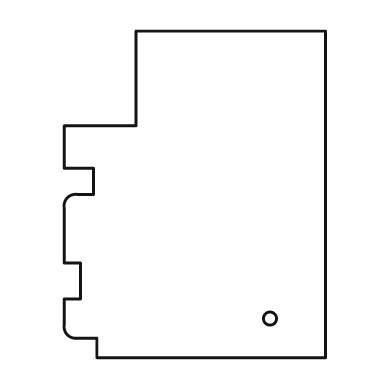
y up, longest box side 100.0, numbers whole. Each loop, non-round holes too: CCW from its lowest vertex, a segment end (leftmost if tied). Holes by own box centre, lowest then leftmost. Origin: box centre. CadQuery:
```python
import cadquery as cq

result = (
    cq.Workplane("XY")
    .moveTo(-30.0, -50.0)
    .lineTo(40.0, -50.0)
    .lineTo(40.0, 50.0)
    .lineTo(-18.0, 50.0)
    .lineTo(-18.0, 21.0)
    .lineTo(-40.0, 21.0)
    .lineTo(-40.0, 8.0)
    .lineTo(-31.0, 8.0)
    .lineTo(-31.0, 0.0)
    .lineTo(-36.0, 0.0)
    .threePointArc((-39.0, -1.0), (-40.0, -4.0))
    .lineTo(-40.0, -21.0)
    .lineTo(-35.0, -21.0)
    .lineTo(-35.0, -32.0)
    .lineTo(-40.0, -32.0)
    .lineTo(-40.0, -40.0)
    .threePointArc((-39.0, -43.0), (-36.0, -44.0))
    .lineTo(-30.0, -44.0)
    .close()
    .moveTo(23.0, -38.0)
    .circle(2.0)
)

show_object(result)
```